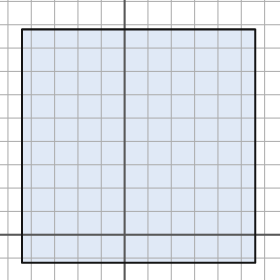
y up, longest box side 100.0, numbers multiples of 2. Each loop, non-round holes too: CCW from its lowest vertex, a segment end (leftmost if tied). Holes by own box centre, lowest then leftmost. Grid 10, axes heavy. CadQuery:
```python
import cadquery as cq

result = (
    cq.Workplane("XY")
    .moveTo(-44.0, -12.0)
    .lineTo(56.0, -12.0)
    .lineTo(56.0, 88.0)
    .lineTo(-44.0, 88.0)
    .close()
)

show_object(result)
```